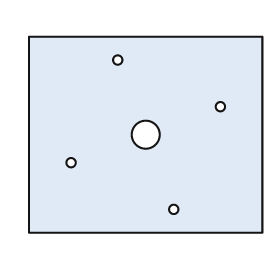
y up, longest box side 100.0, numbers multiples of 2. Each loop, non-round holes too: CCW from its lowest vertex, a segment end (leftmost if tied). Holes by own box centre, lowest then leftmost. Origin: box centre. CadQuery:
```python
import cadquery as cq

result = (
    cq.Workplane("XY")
    .moveTo(-50.0, -42.0)
    .lineTo(50.0, -42.0)
    .lineTo(50.0, 42.0)
    .lineTo(-50.0, 42.0)
    .close()
    .moveTo(12.0, -32.0)
    .circle(2.0)
    .moveTo(-32.0, -12.0)
    .circle(2.0)
    .moveTo(0.0, 0.0)
    .circle(6.0)
    .moveTo(32.0, 12.0)
    .circle(2.0)
    .moveTo(-12.0, 32.0)
    .circle(2.0)
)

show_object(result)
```